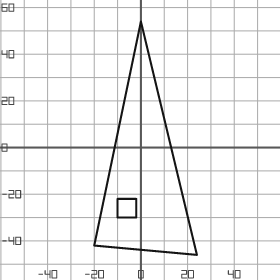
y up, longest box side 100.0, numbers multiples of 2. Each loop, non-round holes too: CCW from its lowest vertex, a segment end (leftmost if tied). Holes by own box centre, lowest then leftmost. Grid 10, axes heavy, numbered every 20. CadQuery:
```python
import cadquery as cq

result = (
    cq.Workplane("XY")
    .moveTo(24.0, -46.0)
    .lineTo(0.0, 54.0)
    .lineTo(-20.0, -42.0)
    .close()
    .moveTo(-10.0, -30.0)
    .lineTo(-2.0, -30.0)
    .lineTo(-2.0, -22.0)
    .lineTo(-10.0, -22.0)
    .close()
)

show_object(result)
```